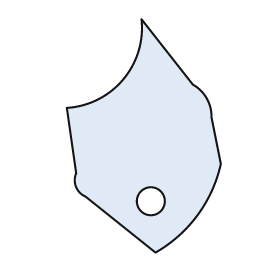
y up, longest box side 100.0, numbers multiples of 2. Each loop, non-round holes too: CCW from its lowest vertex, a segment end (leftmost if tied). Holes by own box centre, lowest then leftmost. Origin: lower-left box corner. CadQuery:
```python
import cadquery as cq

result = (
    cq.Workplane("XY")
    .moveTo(38.0, 0.0)
    .threePointArc((56.0, 16.0), (66.0, 38.0))
    .lineTo(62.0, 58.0)
    .threePointArc((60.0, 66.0), (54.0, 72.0))
    .lineTo(32.0, 100.0)
    .threePointArc((24.0, 74.0), (0.0, 62.0))
    .lineTo(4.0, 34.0)
    .threePointArc((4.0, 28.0), (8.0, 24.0))
    .close()
    .moveTo(36.0, 22.0)
    .circle(6.0)
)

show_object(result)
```